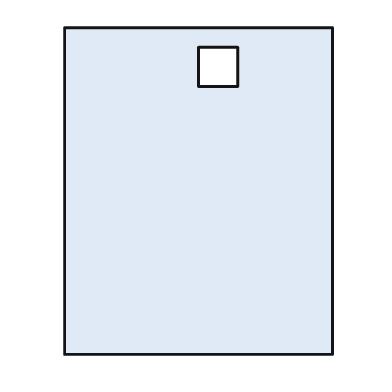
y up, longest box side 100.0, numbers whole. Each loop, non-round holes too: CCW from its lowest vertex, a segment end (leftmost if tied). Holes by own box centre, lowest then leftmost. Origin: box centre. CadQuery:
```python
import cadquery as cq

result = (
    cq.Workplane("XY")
    .moveTo(-41.0, -50.0)
    .lineTo(41.0, -50.0)
    .lineTo(41.0, 50.0)
    .lineTo(-41.0, 50.0)
    .close()
    .moveTo(0.0, 32.0)
    .lineTo(12.0, 32.0)
    .lineTo(12.0, 44.0)
    .lineTo(0.0, 44.0)
    .close()
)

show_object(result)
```